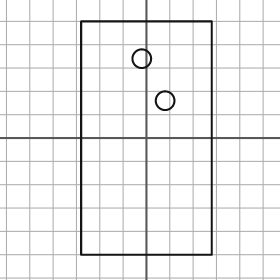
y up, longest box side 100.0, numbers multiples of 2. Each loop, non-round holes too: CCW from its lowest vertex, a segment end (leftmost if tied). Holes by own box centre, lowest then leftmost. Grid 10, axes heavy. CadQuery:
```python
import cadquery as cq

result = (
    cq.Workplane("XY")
    .moveTo(-28.0, -50.0)
    .lineTo(28.0, -50.0)
    .lineTo(28.0, 50.0)
    .lineTo(-28.0, 50.0)
    .close()
    .moveTo(8.0, 16.0)
    .circle(4.0)
    .moveTo(-2.0, 34.0)
    .circle(4.0)
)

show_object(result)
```